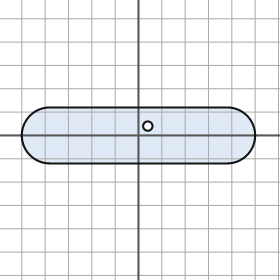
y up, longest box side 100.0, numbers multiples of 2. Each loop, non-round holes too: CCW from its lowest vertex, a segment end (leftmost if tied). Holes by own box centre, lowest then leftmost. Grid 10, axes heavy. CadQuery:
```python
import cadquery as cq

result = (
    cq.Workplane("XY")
    .moveTo(-38.0, -12.0)
    .lineTo(38.0, -12.0)
    .threePointArc((50.0, 0.0), (38.0, 12.0))
    .lineTo(-38.0, 12.0)
    .threePointArc((-50.0, 0.0), (-38.0, -12.0))
    .close()
    .moveTo(4.0, 4.0)
    .circle(2.0)
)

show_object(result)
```